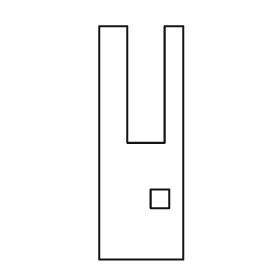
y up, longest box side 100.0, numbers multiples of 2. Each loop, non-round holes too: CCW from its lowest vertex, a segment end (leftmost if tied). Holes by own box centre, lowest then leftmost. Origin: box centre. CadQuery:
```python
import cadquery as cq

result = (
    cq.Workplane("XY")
    .moveTo(-18.0, -50.0)
    .lineTo(18.0, -50.0)
    .lineTo(18.0, 50.0)
    .lineTo(10.0, 50.0)
    .lineTo(10.0, 0.0)
    .lineTo(-6.0, 0.0)
    .lineTo(-6.0, 50.0)
    .lineTo(-18.0, 50.0)
    .close()
    .moveTo(4.0, -28.0)
    .lineTo(12.0, -28.0)
    .lineTo(12.0, -20.0)
    .lineTo(4.0, -20.0)
    .close()
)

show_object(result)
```